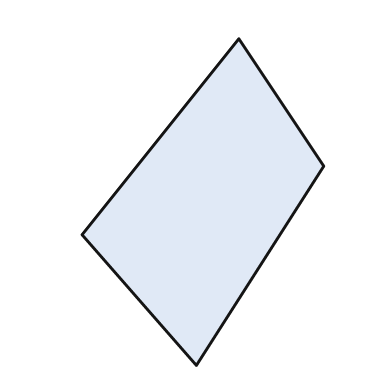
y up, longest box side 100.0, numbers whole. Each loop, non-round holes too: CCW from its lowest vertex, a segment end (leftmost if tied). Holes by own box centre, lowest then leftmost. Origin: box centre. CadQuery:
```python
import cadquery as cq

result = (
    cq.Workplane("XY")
    .moveTo(-2.0, -50.0)
    .lineTo(37.0, 11.0)
    .lineTo(11.0, 50.0)
    .lineTo(-37.0, -10.0)
    .close()
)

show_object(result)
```